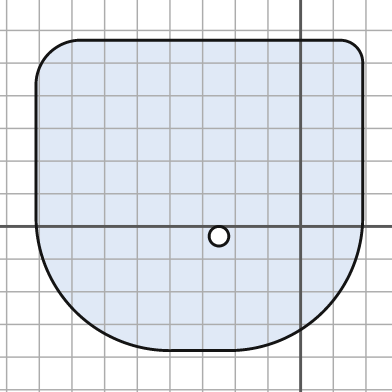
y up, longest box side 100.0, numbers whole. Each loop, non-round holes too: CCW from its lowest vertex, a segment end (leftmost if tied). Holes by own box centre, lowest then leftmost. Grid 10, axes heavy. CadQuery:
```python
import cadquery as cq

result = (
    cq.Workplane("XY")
    .moveTo(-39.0, -38.0)
    .lineTo(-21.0, -38.0)
    .threePointArc((7.0, -26.0), (19.0, 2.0))
    .lineTo(19.0, 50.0)
    .threePointArc((17.0, 55.0), (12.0, 57.0))
    .lineTo(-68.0, 57.0)
    .threePointArc((-77.0, 53.0), (-81.0, 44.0))
    .lineTo(-81.0, 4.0)
    .threePointArc((-69.0, -26.0), (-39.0, -38.0))
    .close()
    .moveTo(-25.0, -3.0)
    .circle(3.0)
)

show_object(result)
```